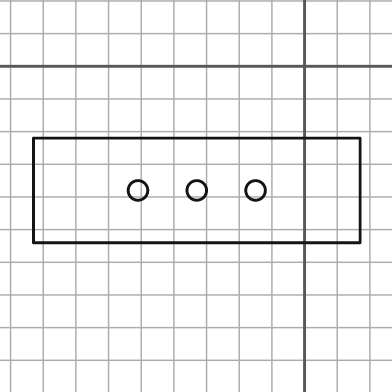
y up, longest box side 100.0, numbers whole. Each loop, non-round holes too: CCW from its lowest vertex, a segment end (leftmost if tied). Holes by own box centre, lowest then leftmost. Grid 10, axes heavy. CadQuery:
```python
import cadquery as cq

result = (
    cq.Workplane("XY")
    .moveTo(-83.0, -54.0)
    .lineTo(17.0, -54.0)
    .lineTo(17.0, -22.0)
    .lineTo(-83.0, -22.0)
    .close()
    .moveTo(-51.0, -38.0)
    .circle(3.0)
    .moveTo(-33.0, -38.0)
    .circle(3.0)
    .moveTo(-15.0, -38.0)
    .circle(3.0)
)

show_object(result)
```